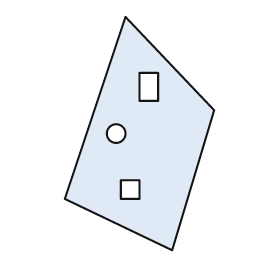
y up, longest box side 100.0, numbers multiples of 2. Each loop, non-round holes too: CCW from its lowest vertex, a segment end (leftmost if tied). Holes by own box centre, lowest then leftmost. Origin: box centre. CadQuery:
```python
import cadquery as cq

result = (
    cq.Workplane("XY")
    .moveTo(14.0, -50.0)
    .lineTo(32.0, 10.0)
    .lineTo(-6.0, 50.0)
    .lineTo(-32.0, -28.0)
    .close()
    .moveTo(-8.0, -28.0)
    .lineTo(0.0, -28.0)
    .lineTo(0.0, -20.0)
    .lineTo(-8.0, -20.0)
    .close()
    .moveTo(-10.0, 0.0)
    .circle(4.0)
    .moveTo(0.0, 14.0)
    .lineTo(8.0, 14.0)
    .lineTo(8.0, 26.0)
    .lineTo(0.0, 26.0)
    .close()
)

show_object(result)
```